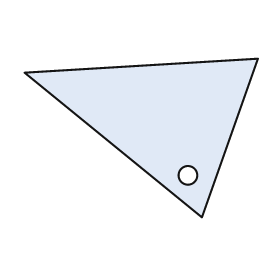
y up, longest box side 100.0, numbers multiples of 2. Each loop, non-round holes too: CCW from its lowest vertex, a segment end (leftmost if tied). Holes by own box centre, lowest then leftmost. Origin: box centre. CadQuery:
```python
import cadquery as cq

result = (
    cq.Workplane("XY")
    .moveTo(26.0, -34.0)
    .lineTo(50.0, 34.0)
    .lineTo(-50.0, 28.0)
    .close()
    .moveTo(20.0, -16.0)
    .circle(4.0)
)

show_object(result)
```